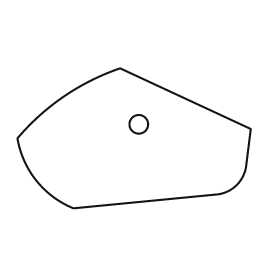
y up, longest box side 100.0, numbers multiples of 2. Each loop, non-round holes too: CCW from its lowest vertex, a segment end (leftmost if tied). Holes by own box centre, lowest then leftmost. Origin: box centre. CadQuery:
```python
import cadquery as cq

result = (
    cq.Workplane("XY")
    .moveTo(-26.0, -30.0)
    .lineTo(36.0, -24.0)
    .threePointArc((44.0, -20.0), (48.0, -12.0))
    .lineTo(50.0, 4.0)
    .lineTo(-6.0, 30.0)
    .threePointArc((-30.0, 18.0), (-50.0, 0.0))
    .threePointArc((-42.0, -18.0), (-26.0, -30.0))
    .close()
    .moveTo(2.0, 6.0)
    .circle(4.0)
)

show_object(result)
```